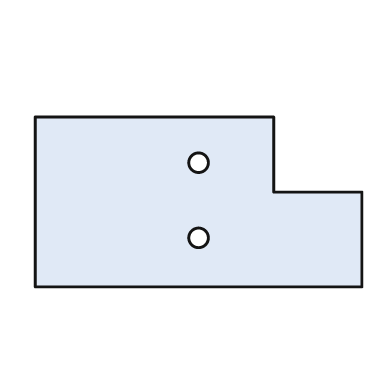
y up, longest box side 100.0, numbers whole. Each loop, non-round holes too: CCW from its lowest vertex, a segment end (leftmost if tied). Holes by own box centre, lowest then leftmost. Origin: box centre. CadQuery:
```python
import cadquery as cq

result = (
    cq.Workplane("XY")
    .moveTo(-50.0, -26.0)
    .lineTo(50.0, -26.0)
    .lineTo(50.0, 3.0)
    .lineTo(23.0, 3.0)
    .lineTo(23.0, 26.0)
    .lineTo(-50.0, 26.0)
    .close()
    .moveTo(0.0, -11.0)
    .circle(3.0)
    .moveTo(0.0, 12.0)
    .circle(3.0)
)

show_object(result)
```